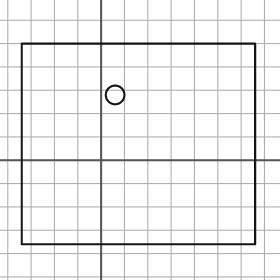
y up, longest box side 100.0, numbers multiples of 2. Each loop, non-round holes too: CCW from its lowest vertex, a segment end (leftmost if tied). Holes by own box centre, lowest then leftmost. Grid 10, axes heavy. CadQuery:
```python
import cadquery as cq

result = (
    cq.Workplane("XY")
    .moveTo(-34.0, -36.0)
    .lineTo(66.0, -36.0)
    .lineTo(66.0, 50.0)
    .lineTo(-34.0, 50.0)
    .close()
    .moveTo(6.0, 28.0)
    .circle(4.0)
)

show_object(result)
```